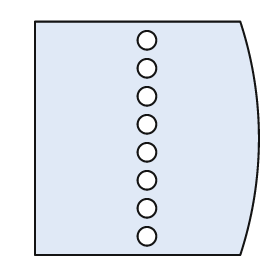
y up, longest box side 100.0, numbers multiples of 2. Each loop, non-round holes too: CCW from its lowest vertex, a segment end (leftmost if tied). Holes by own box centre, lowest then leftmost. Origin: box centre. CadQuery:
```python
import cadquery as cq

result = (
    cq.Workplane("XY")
    .moveTo(-48.0, -50.0)
    .lineTo(40.0, -50.0)
    .threePointArc((48.0, 0.0), (40.0, 50.0))
    .lineTo(-48.0, 50.0)
    .close()
    .moveTo(0.0, -42.0)
    .circle(4.0)
    .moveTo(0.0, -30.0)
    .circle(4.0)
    .moveTo(0.0, -18.0)
    .circle(4.0)
    .moveTo(0.0, -6.0)
    .circle(4.0)
    .moveTo(0.0, 6.0)
    .circle(4.0)
    .moveTo(0.0, 18.0)
    .circle(4.0)
    .moveTo(0.0, 30.0)
    .circle(4.0)
    .moveTo(0.0, 42.0)
    .circle(4.0)
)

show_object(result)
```